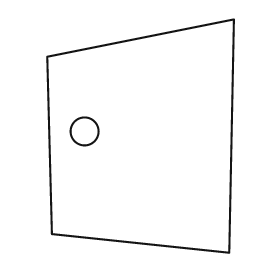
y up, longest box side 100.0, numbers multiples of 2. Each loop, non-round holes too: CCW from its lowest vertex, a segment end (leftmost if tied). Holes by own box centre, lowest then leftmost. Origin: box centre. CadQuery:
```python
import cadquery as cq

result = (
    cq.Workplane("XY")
    .moveTo(38.0, -50.0)
    .lineTo(40.0, 50.0)
    .lineTo(-40.0, 34.0)
    .lineTo(-38.0, -42.0)
    .close()
    .moveTo(-24.0, 2.0)
    .circle(6.0)
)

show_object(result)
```